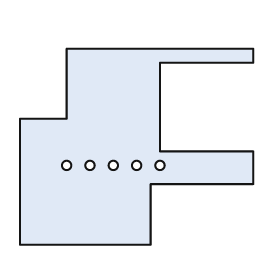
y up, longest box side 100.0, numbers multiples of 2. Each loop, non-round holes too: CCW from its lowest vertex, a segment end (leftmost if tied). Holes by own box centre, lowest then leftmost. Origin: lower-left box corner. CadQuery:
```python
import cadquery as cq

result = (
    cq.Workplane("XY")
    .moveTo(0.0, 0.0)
    .lineTo(56.0, 0.0)
    .lineTo(56.0, 26.0)
    .lineTo(100.0, 26.0)
    .lineTo(100.0, 40.0)
    .lineTo(60.0, 40.0)
    .lineTo(60.0, 78.0)
    .lineTo(100.0, 78.0)
    .lineTo(100.0, 84.0)
    .lineTo(20.0, 84.0)
    .lineTo(20.0, 54.0)
    .lineTo(0.0, 54.0)
    .close()
    .moveTo(20.0, 34.0)
    .circle(2.0)
    .moveTo(30.0, 34.0)
    .circle(2.0)
    .moveTo(40.0, 34.0)
    .circle(2.0)
    .moveTo(50.0, 34.0)
    .circle(2.0)
    .moveTo(60.0, 34.0)
    .circle(2.0)
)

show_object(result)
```